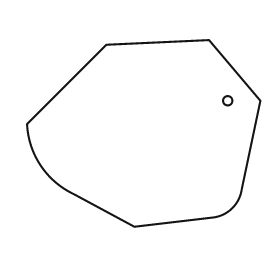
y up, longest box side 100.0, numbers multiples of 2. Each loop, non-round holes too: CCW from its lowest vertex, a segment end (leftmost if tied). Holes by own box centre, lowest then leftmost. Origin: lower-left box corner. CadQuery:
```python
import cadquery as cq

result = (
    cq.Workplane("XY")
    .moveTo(46.0, 0.0)
    .lineTo(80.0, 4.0)
    .threePointArc((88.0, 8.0), (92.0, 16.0))
    .lineTo(100.0, 54.0)
    .lineTo(78.0, 80.0)
    .lineTo(34.0, 78.0)
    .lineTo(0.0, 44.0)
    .threePointArc((6.0, 26.0), (20.0, 14.0))
    .close()
    .moveTo(86.0, 54.0)
    .circle(2.0)
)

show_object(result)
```